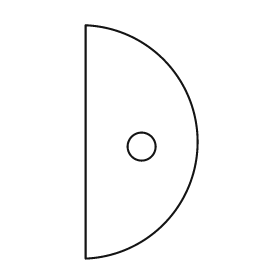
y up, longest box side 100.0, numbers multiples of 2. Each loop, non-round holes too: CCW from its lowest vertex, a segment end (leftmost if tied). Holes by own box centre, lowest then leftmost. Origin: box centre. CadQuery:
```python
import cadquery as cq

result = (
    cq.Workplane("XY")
    .moveTo(-24.0, -50.0)
    .threePointArc((24.0, 0.0), (-24.0, 50.0))
    .close()
    .moveTo(0.0, -2.0)
    .circle(6.0)
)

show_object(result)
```